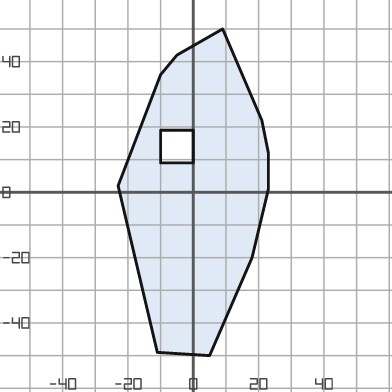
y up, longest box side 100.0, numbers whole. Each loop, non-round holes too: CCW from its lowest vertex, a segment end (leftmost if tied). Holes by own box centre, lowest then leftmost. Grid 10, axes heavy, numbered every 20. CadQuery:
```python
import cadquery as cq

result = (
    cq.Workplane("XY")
    .moveTo(5.0, -50.0)
    .lineTo(18.0, -20.0)
    .lineTo(23.0, 1.0)
    .lineTo(23.0, 12.0)
    .lineTo(21.0, 22.0)
    .lineTo(9.0, 50.0)
    .lineTo(-5.0, 42.0)
    .lineTo(-10.0, 36.0)
    .lineTo(-23.0, 2.0)
    .lineTo(-11.0, -49.0)
    .close()
    .moveTo(-10.0, 9.0)
    .lineTo(0.0, 9.0)
    .lineTo(0.0, 19.0)
    .lineTo(-10.0, 19.0)
    .close()
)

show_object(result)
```